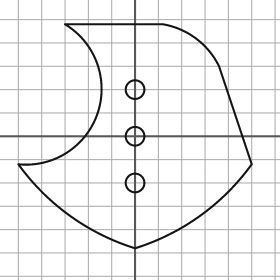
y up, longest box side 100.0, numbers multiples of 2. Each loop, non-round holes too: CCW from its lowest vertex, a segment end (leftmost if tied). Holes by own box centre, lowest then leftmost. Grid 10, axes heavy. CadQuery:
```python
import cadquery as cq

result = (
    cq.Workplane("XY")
    .moveTo(0.0, -48.0)
    .threePointArc((28.0, -34.0), (50.0, -12.0))
    .lineTo(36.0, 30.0)
    .threePointArc((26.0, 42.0), (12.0, 48.0))
    .lineTo(-30.0, 48.0)
    .threePointArc((-16.0, 10.0), (-50.0, -12.0))
    .threePointArc((-28.0, -34.0), (0.0, -48.0))
    .close()
    .moveTo(0.0, -20.0)
    .circle(4.0)
    .moveTo(0.0, 0.0)
    .circle(4.0)
    .moveTo(0.0, 20.0)
    .circle(4.0)
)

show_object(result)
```